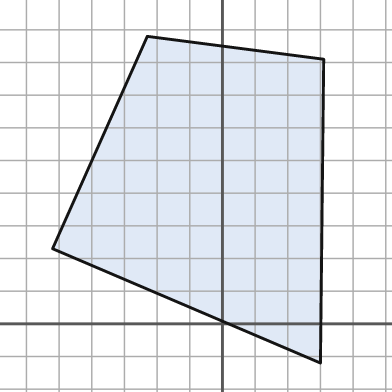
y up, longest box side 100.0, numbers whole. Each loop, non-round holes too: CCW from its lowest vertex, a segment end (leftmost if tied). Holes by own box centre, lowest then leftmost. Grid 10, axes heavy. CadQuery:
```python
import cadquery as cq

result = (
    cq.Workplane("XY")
    .moveTo(30.0, -12.0)
    .lineTo(31.0, 81.0)
    .lineTo(-23.0, 88.0)
    .lineTo(-52.0, 23.0)
    .close()
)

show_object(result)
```